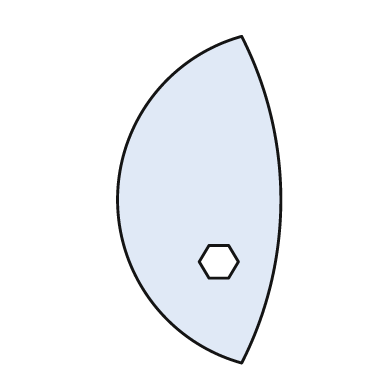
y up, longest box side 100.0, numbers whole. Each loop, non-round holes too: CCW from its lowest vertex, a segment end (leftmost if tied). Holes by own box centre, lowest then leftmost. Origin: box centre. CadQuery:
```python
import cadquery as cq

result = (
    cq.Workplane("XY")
    .moveTo(13.0, -50.0)
    .threePointArc((25.0, 0.0), (13.0, 50.0))
    .threePointArc((-25.0, 0.0), (13.0, -50.0))
    .close()
    .moveTo(3.0, -24.0)
    .lineTo(9.0, -24.0)
    .lineTo(12.0, -19.0)
    .lineTo(9.0, -14.0)
    .lineTo(3.0, -14.0)
    .lineTo(0.0, -19.0)
    .close()
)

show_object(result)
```